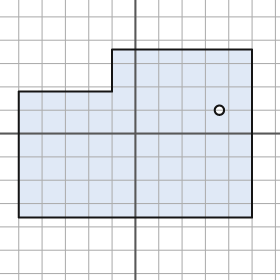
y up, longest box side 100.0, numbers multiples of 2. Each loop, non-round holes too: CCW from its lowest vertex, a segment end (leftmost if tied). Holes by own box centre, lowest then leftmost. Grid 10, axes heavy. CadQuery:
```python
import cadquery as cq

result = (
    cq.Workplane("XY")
    .moveTo(-50.0, -36.0)
    .lineTo(50.0, -36.0)
    .lineTo(50.0, 36.0)
    .lineTo(-10.0, 36.0)
    .lineTo(-10.0, 18.0)
    .lineTo(-50.0, 18.0)
    .close()
    .moveTo(36.0, 10.0)
    .circle(2.0)
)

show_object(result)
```